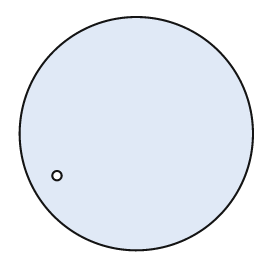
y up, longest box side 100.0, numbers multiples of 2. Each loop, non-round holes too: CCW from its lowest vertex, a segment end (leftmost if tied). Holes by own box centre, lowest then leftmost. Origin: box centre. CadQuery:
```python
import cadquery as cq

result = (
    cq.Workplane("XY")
    .moveTo(0.0, 0.0)
    .circle(50.0)
    .moveTo(-34.0, -18.0)
    .circle(2.0)
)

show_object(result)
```